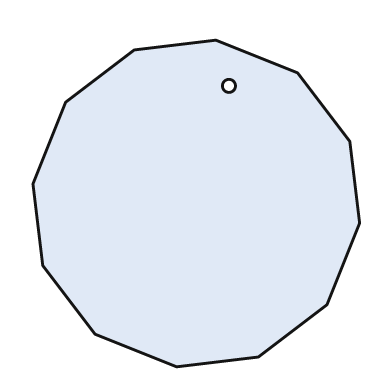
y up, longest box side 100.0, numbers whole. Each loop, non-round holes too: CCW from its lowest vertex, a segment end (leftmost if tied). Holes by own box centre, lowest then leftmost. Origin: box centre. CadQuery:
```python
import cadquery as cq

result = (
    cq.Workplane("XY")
    .moveTo(-6.0, -50.0)
    .lineTo(19.0, -47.0)
    .lineTo(40.0, -31.0)
    .lineTo(50.0, -6.0)
    .lineTo(47.0, 19.0)
    .lineTo(31.0, 40.0)
    .lineTo(6.0, 50.0)
    .lineTo(-19.0, 47.0)
    .lineTo(-40.0, 31.0)
    .lineTo(-50.0, 6.0)
    .lineTo(-47.0, -19.0)
    .lineTo(-31.0, -40.0)
    .close()
    .moveTo(10.0, 36.0)
    .circle(2.0)
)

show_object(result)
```